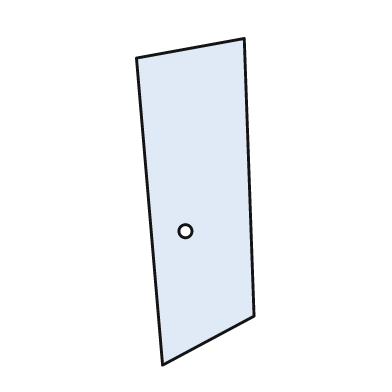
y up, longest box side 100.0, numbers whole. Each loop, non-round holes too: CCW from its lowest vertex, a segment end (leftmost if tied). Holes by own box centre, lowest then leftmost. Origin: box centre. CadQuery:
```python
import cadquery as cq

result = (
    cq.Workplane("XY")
    .moveTo(-10.0, -50.0)
    .lineTo(18.0, -35.0)
    .lineTo(15.0, 50.0)
    .lineTo(-18.0, 44.0)
    .close()
    .moveTo(-3.0, -9.0)
    .circle(2.0)
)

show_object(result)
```